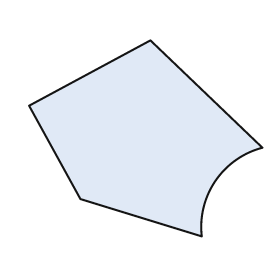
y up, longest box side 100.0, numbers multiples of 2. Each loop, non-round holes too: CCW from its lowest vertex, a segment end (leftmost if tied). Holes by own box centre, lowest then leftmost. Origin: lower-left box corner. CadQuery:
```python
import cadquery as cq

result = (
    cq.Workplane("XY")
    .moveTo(74.0, 0.0)
    .threePointArc((80.0, 24.0), (100.0, 38.0))
    .lineTo(52.0, 84.0)
    .lineTo(0.0, 56.0)
    .lineTo(22.0, 16.0)
    .close()
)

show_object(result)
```